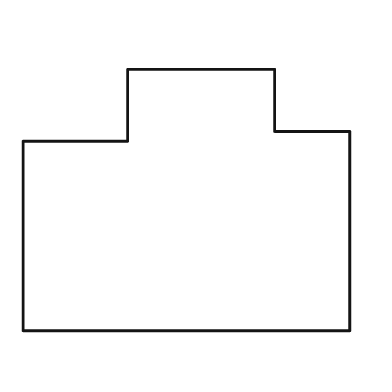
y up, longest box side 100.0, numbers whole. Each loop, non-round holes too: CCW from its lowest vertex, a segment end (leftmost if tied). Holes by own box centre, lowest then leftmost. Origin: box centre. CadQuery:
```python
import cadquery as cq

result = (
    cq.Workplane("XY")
    .moveTo(-50.0, -40.0)
    .lineTo(50.0, -40.0)
    .lineTo(50.0, 21.0)
    .lineTo(27.0, 21.0)
    .lineTo(27.0, 40.0)
    .lineTo(-18.0, 40.0)
    .lineTo(-18.0, 18.0)
    .lineTo(-50.0, 18.0)
    .close()
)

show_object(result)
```